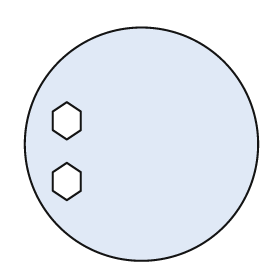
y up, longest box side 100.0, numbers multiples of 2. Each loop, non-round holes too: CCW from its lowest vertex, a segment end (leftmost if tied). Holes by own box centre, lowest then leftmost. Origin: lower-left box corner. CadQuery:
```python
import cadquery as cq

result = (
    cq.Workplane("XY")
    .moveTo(50.0, 50.0)
    .circle(50.0)
    .moveTo(18.0, 26.0)
    .lineTo(24.0, 30.0)
    .lineTo(24.0, 38.0)
    .lineTo(18.0, 42.0)
    .lineTo(12.0, 38.0)
    .lineTo(12.0, 30.0)
    .close()
    .moveTo(18.0, 52.0)
    .lineTo(24.0, 56.0)
    .lineTo(24.0, 64.0)
    .lineTo(18.0, 68.0)
    .lineTo(12.0, 64.0)
    .lineTo(12.0, 56.0)
    .close()
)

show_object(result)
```